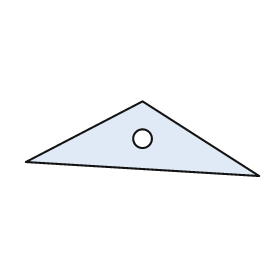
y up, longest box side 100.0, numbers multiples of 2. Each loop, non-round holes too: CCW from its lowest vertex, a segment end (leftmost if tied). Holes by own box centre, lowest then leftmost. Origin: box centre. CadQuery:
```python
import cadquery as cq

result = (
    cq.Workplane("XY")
    .moveTo(50.0, -16.0)
    .lineTo(0.0, 16.0)
    .lineTo(-50.0, -10.0)
    .close()
    .moveTo(0.0, 0.0)
    .circle(4.0)
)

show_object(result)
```